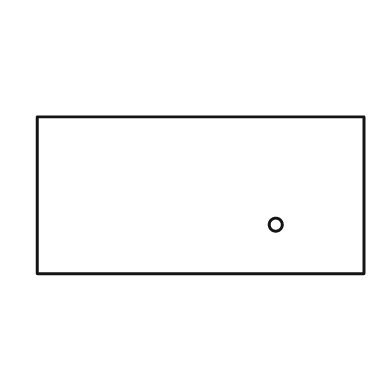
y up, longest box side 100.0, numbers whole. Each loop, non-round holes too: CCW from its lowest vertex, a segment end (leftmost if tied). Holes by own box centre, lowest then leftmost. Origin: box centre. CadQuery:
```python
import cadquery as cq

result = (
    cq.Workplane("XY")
    .moveTo(-50.0, -24.0)
    .lineTo(50.0, -24.0)
    .lineTo(50.0, 24.0)
    .lineTo(-50.0, 24.0)
    .close()
    .moveTo(23.0, -9.0)
    .circle(2.0)
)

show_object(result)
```